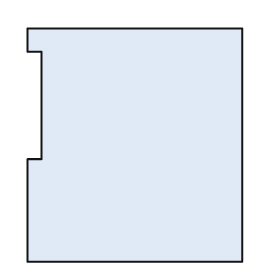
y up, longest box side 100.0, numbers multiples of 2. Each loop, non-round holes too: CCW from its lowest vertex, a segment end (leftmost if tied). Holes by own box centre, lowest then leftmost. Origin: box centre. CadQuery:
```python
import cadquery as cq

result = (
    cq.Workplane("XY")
    .moveTo(-46.0, -50.0)
    .lineTo(46.0, -50.0)
    .lineTo(46.0, 50.0)
    .lineTo(-46.0, 50.0)
    .lineTo(-46.0, 40.0)
    .lineTo(-40.0, 40.0)
    .lineTo(-40.0, -6.0)
    .lineTo(-46.0, -6.0)
    .close()
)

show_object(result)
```